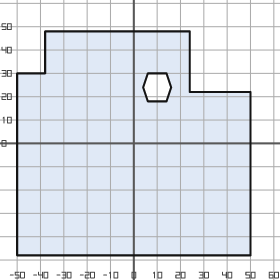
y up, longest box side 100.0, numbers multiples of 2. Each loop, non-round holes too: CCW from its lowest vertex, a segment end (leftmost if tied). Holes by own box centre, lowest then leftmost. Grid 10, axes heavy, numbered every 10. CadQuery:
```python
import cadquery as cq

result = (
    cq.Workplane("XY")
    .moveTo(-50.0, -48.0)
    .lineTo(50.0, -48.0)
    .lineTo(50.0, 22.0)
    .lineTo(24.0, 22.0)
    .lineTo(24.0, 48.0)
    .lineTo(-38.0, 48.0)
    .lineTo(-38.0, 30.0)
    .lineTo(-50.0, 30.0)
    .close()
    .moveTo(6.0, 18.0)
    .lineTo(14.0, 18.0)
    .lineTo(16.0, 24.0)
    .lineTo(14.0, 30.0)
    .lineTo(6.0, 30.0)
    .lineTo(4.0, 24.0)
    .close()
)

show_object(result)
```